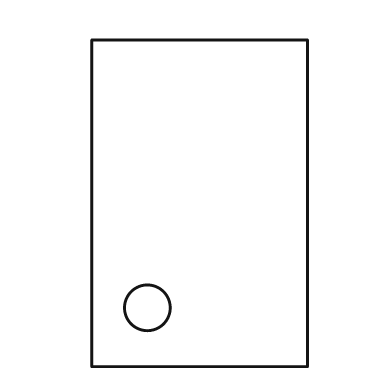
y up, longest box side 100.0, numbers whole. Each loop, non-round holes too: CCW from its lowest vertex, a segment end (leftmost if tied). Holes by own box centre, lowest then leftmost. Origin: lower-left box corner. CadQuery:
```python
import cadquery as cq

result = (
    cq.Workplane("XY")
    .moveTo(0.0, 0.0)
    .lineTo(66.0, 0.0)
    .lineTo(66.0, 100.0)
    .lineTo(0.0, 100.0)
    .close()
    .moveTo(17.0, 18.0)
    .circle(7.0)
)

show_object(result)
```